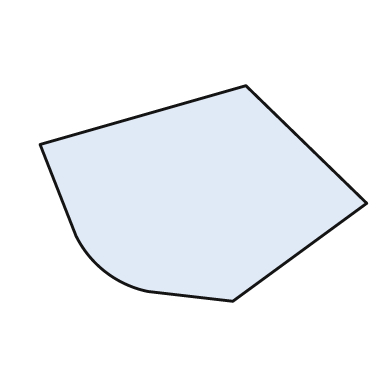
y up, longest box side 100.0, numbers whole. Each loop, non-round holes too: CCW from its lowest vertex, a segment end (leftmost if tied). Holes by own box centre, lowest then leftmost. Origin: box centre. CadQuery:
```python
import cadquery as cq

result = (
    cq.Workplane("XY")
    .moveTo(9.0, -33.0)
    .lineTo(50.0, -3.0)
    .lineTo(13.0, 33.0)
    .lineTo(-50.0, 15.0)
    .lineTo(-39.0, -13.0)
    .threePointArc((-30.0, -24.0), (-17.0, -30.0))
    .close()
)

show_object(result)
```